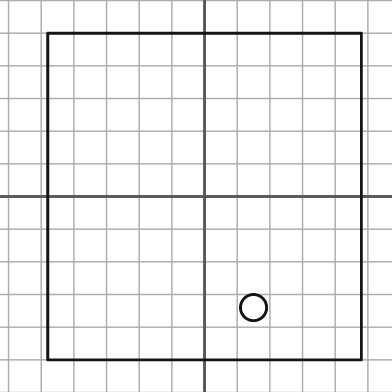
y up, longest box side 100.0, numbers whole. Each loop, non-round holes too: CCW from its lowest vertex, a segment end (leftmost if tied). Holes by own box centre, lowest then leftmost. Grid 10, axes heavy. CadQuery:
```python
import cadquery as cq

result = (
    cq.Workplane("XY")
    .moveTo(-48.0, -50.0)
    .lineTo(48.0, -50.0)
    .lineTo(48.0, 50.0)
    .lineTo(-48.0, 50.0)
    .close()
    .moveTo(15.0, -34.0)
    .circle(4.0)
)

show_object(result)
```